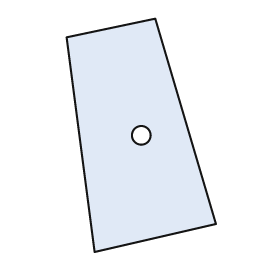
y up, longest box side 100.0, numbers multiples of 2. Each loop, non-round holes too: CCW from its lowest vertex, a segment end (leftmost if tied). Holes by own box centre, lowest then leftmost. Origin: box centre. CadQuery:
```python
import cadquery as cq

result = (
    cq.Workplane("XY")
    .moveTo(-20.0, -50.0)
    .lineTo(32.0, -38.0)
    .lineTo(6.0, 50.0)
    .lineTo(-32.0, 42.0)
    .close()
    .moveTo(0.0, 0.0)
    .circle(4.0)
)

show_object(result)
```